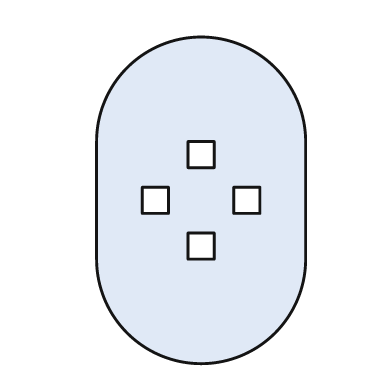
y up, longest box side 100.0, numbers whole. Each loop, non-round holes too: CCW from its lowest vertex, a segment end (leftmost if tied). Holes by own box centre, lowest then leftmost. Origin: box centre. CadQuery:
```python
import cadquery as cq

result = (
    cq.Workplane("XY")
    .moveTo(-32.0, -18.0)
    .threePointArc((0.0, -50.0), (32.0, -18.0))
    .lineTo(32.0, 18.0)
    .threePointArc((0.0, 50.0), (-32.0, 18.0))
    .close()
    .moveTo(-4.0, -18.0)
    .lineTo(4.0, -18.0)
    .lineTo(4.0, -10.0)
    .lineTo(-4.0, -10.0)
    .close()
    .moveTo(-18.0, -4.0)
    .lineTo(-10.0, -4.0)
    .lineTo(-10.0, 4.0)
    .lineTo(-18.0, 4.0)
    .close()
    .moveTo(10.0, -4.0)
    .lineTo(18.0, -4.0)
    .lineTo(18.0, 4.0)
    .lineTo(10.0, 4.0)
    .close()
    .moveTo(-4.0, 10.0)
    .lineTo(4.0, 10.0)
    .lineTo(4.0, 18.0)
    .lineTo(-4.0, 18.0)
    .close()
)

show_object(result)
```